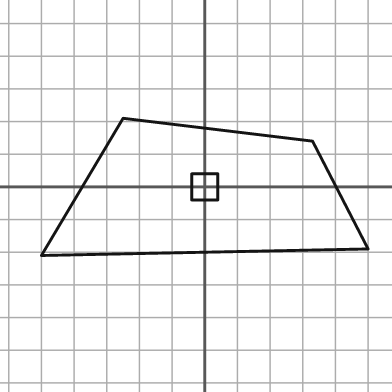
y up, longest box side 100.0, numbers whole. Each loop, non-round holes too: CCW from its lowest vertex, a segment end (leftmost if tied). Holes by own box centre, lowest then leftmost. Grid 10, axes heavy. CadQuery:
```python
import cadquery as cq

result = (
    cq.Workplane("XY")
    .moveTo(-50.0, -21.0)
    .lineTo(50.0, -19.0)
    .lineTo(33.0, 14.0)
    .lineTo(-25.0, 21.0)
    .close()
    .moveTo(-4.0, -4.0)
    .lineTo(4.0, -4.0)
    .lineTo(4.0, 4.0)
    .lineTo(-4.0, 4.0)
    .close()
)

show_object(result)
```